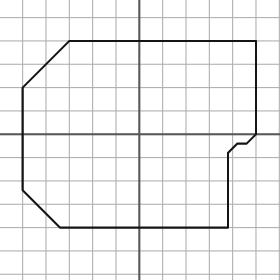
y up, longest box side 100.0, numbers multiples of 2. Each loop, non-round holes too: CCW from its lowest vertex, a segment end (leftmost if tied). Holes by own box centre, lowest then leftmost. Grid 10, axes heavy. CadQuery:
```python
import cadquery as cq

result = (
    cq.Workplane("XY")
    .moveTo(-34.0, -40.0)
    .lineTo(38.0, -40.0)
    .lineTo(38.0, -8.0)
    .lineTo(42.0, -4.0)
    .lineTo(46.0, -4.0)
    .lineTo(50.0, 0.0)
    .lineTo(50.0, 40.0)
    .lineTo(-30.0, 40.0)
    .lineTo(-50.0, 20.0)
    .lineTo(-50.0, -24.0)
    .close()
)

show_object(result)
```